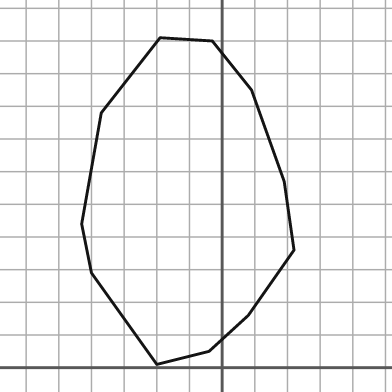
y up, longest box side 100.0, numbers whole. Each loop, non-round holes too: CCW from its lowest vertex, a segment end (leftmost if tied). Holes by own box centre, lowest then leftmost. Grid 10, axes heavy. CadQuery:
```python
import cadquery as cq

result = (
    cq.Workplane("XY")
    .moveTo(-20.0, 1.0)
    .lineTo(-4.0, 5.0)
    .lineTo(8.0, 16.0)
    .lineTo(22.0, 36.0)
    .lineTo(19.0, 57.0)
    .lineTo(9.0, 85.0)
    .lineTo(-3.0, 100.0)
    .lineTo(-19.0, 101.0)
    .lineTo(-37.0, 78.0)
    .lineTo(-43.0, 44.0)
    .lineTo(-40.0, 29.0)
    .close()
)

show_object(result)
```